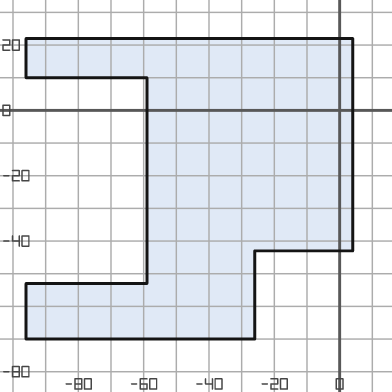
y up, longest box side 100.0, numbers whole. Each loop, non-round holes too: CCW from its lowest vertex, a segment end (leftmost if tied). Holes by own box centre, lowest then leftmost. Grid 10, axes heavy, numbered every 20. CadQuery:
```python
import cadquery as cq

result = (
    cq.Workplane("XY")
    .moveTo(-96.0, -70.0)
    .lineTo(-26.0, -70.0)
    .lineTo(-26.0, -43.0)
    .lineTo(4.0, -43.0)
    .lineTo(4.0, 22.0)
    .lineTo(-96.0, 22.0)
    .lineTo(-96.0, 10.0)
    .lineTo(-59.0, 10.0)
    .lineTo(-59.0, -53.0)
    .lineTo(-96.0, -53.0)
    .close()
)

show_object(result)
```